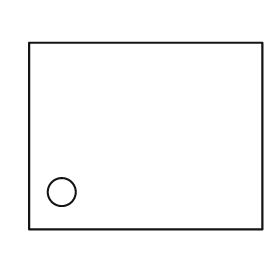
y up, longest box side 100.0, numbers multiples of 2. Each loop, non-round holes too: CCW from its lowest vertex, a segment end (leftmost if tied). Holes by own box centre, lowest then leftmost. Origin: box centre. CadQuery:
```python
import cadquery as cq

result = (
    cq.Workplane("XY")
    .moveTo(-50.0, -40.0)
    .lineTo(50.0, -40.0)
    .lineTo(50.0, 40.0)
    .lineTo(-50.0, 40.0)
    .close()
    .moveTo(-36.0, -24.0)
    .circle(6.0)
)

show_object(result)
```